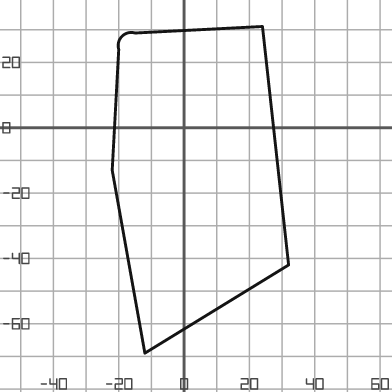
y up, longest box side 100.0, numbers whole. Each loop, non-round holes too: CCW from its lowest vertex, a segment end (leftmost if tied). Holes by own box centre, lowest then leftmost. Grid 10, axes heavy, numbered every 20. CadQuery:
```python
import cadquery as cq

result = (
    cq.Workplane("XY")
    .moveTo(-12.0, -69.0)
    .lineTo(32.0, -42.0)
    .lineTo(24.0, 31.0)
    .lineTo(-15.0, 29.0)
    .threePointArc((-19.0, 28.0), (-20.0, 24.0))
    .lineTo(-22.0, -13.0)
    .close()
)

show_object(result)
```